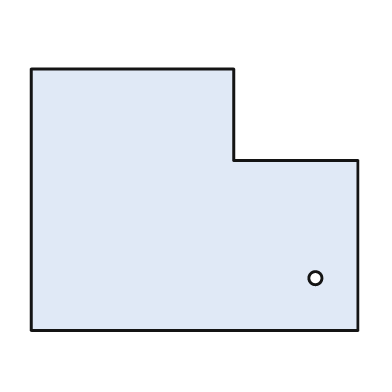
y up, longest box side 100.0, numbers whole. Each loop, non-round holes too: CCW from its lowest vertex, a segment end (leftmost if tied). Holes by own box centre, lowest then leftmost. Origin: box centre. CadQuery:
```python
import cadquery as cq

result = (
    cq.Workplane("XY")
    .moveTo(-50.0, -40.0)
    .lineTo(50.0, -40.0)
    .lineTo(50.0, 12.0)
    .lineTo(12.0, 12.0)
    .lineTo(12.0, 40.0)
    .lineTo(-50.0, 40.0)
    .close()
    .moveTo(37.0, -24.0)
    .circle(2.0)
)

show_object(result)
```